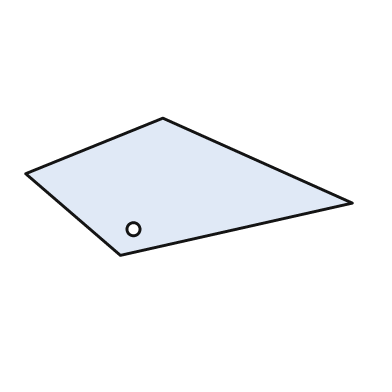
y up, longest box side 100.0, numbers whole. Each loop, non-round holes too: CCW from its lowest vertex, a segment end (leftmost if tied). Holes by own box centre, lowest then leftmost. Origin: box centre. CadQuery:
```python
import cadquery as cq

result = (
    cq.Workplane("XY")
    .moveTo(-21.0, -21.0)
    .lineTo(50.0, -5.0)
    .lineTo(-8.0, 21.0)
    .lineTo(-50.0, 4.0)
    .close()
    .moveTo(-17.0, -13.0)
    .circle(2.0)
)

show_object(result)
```